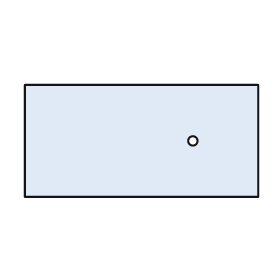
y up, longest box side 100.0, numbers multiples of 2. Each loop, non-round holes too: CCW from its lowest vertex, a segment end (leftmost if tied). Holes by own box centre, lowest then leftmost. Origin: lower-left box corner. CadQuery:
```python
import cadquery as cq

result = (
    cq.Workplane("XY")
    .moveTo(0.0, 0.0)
    .lineTo(100.0, 0.0)
    .lineTo(100.0, 48.0)
    .lineTo(0.0, 48.0)
    .close()
    .moveTo(72.0, 24.0)
    .circle(2.0)
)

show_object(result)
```